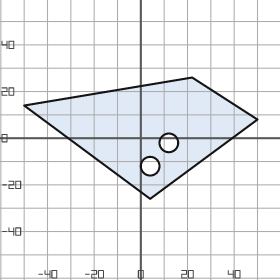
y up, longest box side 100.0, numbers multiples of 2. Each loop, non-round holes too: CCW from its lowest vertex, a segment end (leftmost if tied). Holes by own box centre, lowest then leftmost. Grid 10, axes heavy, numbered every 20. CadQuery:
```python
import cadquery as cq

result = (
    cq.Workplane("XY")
    .moveTo(4.0, -26.0)
    .lineTo(50.0, 8.0)
    .lineTo(22.0, 26.0)
    .lineTo(-50.0, 14.0)
    .close()
    .moveTo(4.0, -12.0)
    .circle(4.0)
    .moveTo(12.0, -2.0)
    .circle(4.0)
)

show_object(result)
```